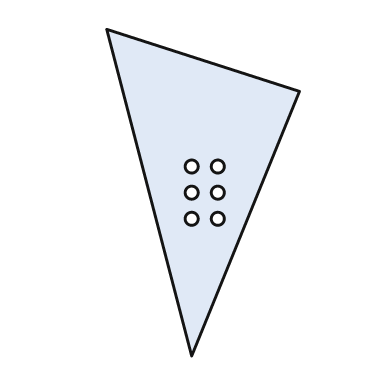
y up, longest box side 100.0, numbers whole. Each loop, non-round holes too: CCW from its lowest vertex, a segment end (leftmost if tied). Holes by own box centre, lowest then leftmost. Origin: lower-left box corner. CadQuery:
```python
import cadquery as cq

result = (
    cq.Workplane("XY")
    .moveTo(26.0, 0.0)
    .lineTo(59.0, 81.0)
    .lineTo(0.0, 100.0)
    .close()
    .moveTo(26.0, 42.0)
    .circle(2.0)
    .moveTo(34.0, 42.0)
    .circle(2.0)
    .moveTo(26.0, 50.0)
    .circle(2.0)
    .moveTo(34.0, 50.0)
    .circle(2.0)
    .moveTo(26.0, 58.0)
    .circle(2.0)
    .moveTo(34.0, 58.0)
    .circle(2.0)
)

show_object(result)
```